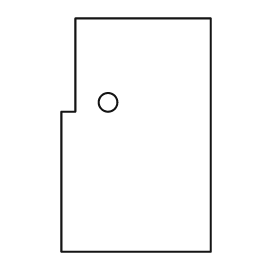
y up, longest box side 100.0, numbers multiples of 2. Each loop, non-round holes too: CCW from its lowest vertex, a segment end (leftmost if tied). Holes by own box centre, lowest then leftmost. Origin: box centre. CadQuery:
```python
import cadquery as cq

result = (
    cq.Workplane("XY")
    .moveTo(-32.0, -50.0)
    .lineTo(32.0, -50.0)
    .lineTo(32.0, 50.0)
    .lineTo(-26.0, 50.0)
    .lineTo(-26.0, 10.0)
    .lineTo(-32.0, 10.0)
    .close()
    .moveTo(-12.0, 14.0)
    .circle(4.0)
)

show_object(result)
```